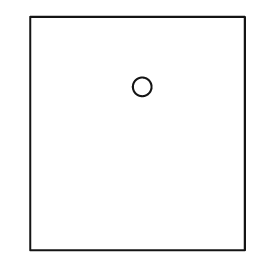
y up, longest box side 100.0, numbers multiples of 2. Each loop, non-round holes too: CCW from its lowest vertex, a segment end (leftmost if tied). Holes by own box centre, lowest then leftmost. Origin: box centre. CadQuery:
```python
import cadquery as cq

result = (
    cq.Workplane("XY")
    .moveTo(-46.0, -50.0)
    .lineTo(46.0, -50.0)
    .lineTo(46.0, 50.0)
    .lineTo(-46.0, 50.0)
    .close()
    .moveTo(2.0, 20.0)
    .circle(4.0)
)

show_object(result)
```